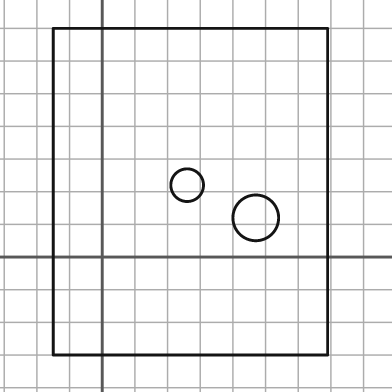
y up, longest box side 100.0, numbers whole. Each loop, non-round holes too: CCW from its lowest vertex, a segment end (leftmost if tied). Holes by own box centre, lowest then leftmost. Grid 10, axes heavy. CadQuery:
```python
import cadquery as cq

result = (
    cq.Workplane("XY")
    .moveTo(-15.0, -30.0)
    .lineTo(69.0, -30.0)
    .lineTo(69.0, 70.0)
    .lineTo(-15.0, 70.0)
    .close()
    .moveTo(47.0, 12.0)
    .circle(7.0)
    .moveTo(26.0, 22.0)
    .circle(5.0)
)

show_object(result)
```